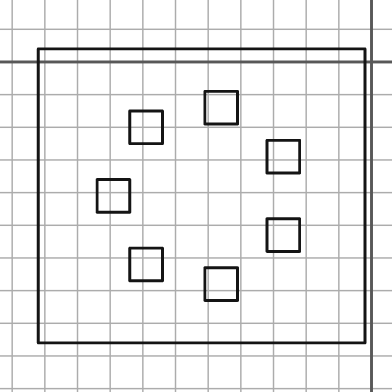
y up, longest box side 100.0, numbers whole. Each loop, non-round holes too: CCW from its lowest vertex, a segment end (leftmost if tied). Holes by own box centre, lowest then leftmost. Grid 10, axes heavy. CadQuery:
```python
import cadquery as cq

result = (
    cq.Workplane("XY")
    .moveTo(-102.0, -86.0)
    .lineTo(-2.0, -86.0)
    .lineTo(-2.0, 4.0)
    .lineTo(-102.0, 4.0)
    .close()
    .moveTo(-51.0, -73.0)
    .lineTo(-41.0, -73.0)
    .lineTo(-41.0, -63.0)
    .lineTo(-51.0, -63.0)
    .close()
    .moveTo(-74.0, -67.0)
    .lineTo(-64.0, -67.0)
    .lineTo(-64.0, -57.0)
    .lineTo(-74.0, -57.0)
    .close()
    .moveTo(-32.0, -58.0)
    .lineTo(-22.0, -58.0)
    .lineTo(-22.0, -48.0)
    .lineTo(-32.0, -48.0)
    .close()
    .moveTo(-84.0, -46.0)
    .lineTo(-74.0, -46.0)
    .lineTo(-74.0, -36.0)
    .lineTo(-84.0, -36.0)
    .close()
    .moveTo(-32.0, -34.0)
    .lineTo(-22.0, -34.0)
    .lineTo(-22.0, -24.0)
    .lineTo(-32.0, -24.0)
    .close()
    .moveTo(-74.0, -25.0)
    .lineTo(-64.0, -25.0)
    .lineTo(-64.0, -15.0)
    .lineTo(-74.0, -15.0)
    .close()
    .moveTo(-51.0, -19.0)
    .lineTo(-41.0, -19.0)
    .lineTo(-41.0, -9.0)
    .lineTo(-51.0, -9.0)
    .close()
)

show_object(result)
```